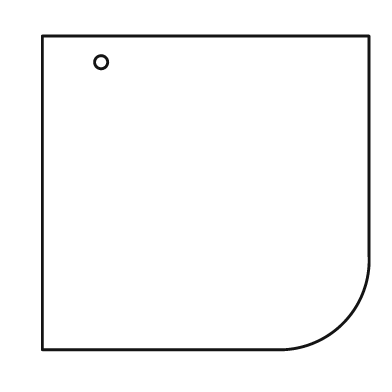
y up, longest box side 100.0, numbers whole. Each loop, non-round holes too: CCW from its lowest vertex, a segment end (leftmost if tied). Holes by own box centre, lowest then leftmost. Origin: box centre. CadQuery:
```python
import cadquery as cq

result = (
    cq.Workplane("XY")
    .moveTo(-50.0, -48.0)
    .lineTo(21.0, -48.0)
    .threePointArc((42.0, -40.0), (50.0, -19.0))
    .lineTo(50.0, 48.0)
    .lineTo(-50.0, 48.0)
    .close()
    .moveTo(-32.0, 40.0)
    .circle(2.0)
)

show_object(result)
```